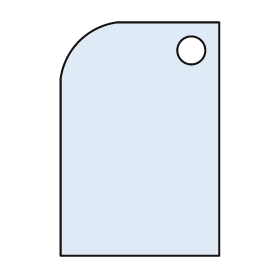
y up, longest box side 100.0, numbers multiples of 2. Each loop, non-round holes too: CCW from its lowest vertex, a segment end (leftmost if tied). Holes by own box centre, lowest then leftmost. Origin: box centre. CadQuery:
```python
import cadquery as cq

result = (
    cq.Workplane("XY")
    .moveTo(-34.0, -50.0)
    .lineTo(34.0, -50.0)
    .lineTo(34.0, 50.0)
    .lineTo(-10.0, 50.0)
    .threePointArc((-26.0, 42.0), (-34.0, 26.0))
    .close()
    .moveTo(22.0, 38.0)
    .circle(6.0)
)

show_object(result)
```